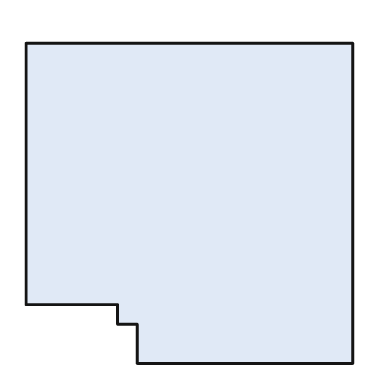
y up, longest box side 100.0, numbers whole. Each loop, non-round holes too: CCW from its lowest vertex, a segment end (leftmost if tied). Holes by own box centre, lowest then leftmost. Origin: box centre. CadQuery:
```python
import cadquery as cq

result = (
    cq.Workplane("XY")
    .moveTo(-16.0, -49.0)
    .lineTo(50.0, -49.0)
    .lineTo(50.0, 49.0)
    .lineTo(-50.0, 49.0)
    .lineTo(-50.0, -31.0)
    .lineTo(-22.0, -31.0)
    .lineTo(-22.0, -37.0)
    .lineTo(-16.0, -37.0)
    .close()
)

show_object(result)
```